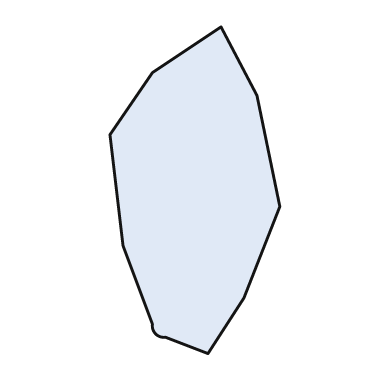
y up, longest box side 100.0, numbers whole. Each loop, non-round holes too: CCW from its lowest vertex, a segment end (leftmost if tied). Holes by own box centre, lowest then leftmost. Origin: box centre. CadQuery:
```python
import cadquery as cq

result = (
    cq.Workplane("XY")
    .moveTo(4.0, -50.0)
    .lineTo(15.0, -33.0)
    .lineTo(26.0, -5.0)
    .lineTo(19.0, 29.0)
    .lineTo(8.0, 50.0)
    .lineTo(-13.0, 36.0)
    .lineTo(-26.0, 17.0)
    .lineTo(-22.0, -17.0)
    .lineTo(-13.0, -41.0)
    .threePointArc((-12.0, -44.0), (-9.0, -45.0))
    .close()
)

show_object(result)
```